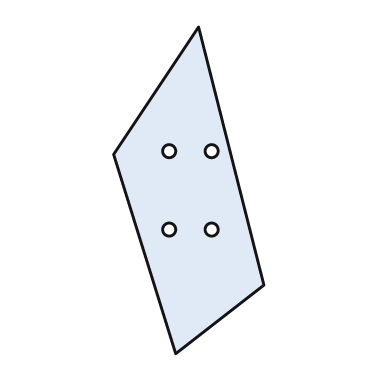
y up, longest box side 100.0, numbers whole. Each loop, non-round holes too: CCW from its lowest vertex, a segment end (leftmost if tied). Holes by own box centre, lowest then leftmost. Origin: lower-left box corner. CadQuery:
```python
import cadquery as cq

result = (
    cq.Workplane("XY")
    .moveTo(19.0, 0.0)
    .lineTo(46.0, 21.0)
    .lineTo(26.0, 100.0)
    .lineTo(0.0, 61.0)
    .close()
    .moveTo(17.0, 38.0)
    .circle(2.0)
    .moveTo(30.0, 38.0)
    .circle(2.0)
    .moveTo(17.0, 62.0)
    .circle(2.0)
    .moveTo(30.0, 62.0)
    .circle(2.0)
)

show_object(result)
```